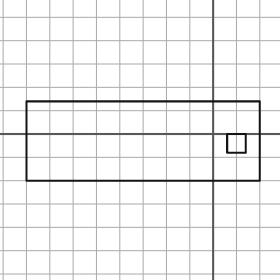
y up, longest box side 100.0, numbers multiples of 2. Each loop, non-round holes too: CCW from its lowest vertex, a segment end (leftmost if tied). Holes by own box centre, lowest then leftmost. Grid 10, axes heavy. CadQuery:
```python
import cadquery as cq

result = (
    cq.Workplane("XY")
    .moveTo(-80.0, -20.0)
    .lineTo(20.0, -20.0)
    .lineTo(20.0, 14.0)
    .lineTo(-80.0, 14.0)
    .close()
    .moveTo(6.0, -8.0)
    .lineTo(14.0, -8.0)
    .lineTo(14.0, 0.0)
    .lineTo(6.0, 0.0)
    .close()
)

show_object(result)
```